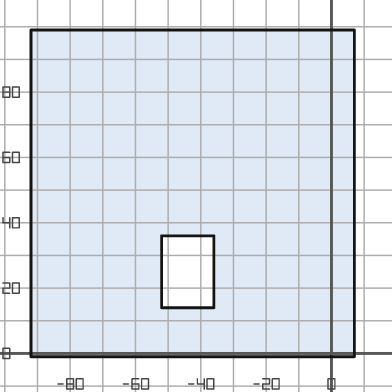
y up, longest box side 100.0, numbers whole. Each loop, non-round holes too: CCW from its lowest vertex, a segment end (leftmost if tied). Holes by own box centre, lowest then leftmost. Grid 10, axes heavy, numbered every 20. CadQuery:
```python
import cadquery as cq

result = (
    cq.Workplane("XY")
    .moveTo(-92.0, -1.0)
    .lineTo(7.0, -1.0)
    .lineTo(7.0, 99.0)
    .lineTo(-92.0, 99.0)
    .close()
    .moveTo(-52.0, 14.0)
    .lineTo(-36.0, 14.0)
    .lineTo(-36.0, 36.0)
    .lineTo(-52.0, 36.0)
    .close()
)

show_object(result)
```